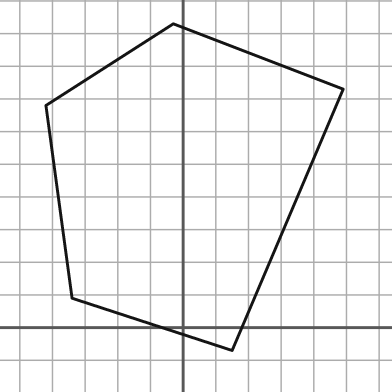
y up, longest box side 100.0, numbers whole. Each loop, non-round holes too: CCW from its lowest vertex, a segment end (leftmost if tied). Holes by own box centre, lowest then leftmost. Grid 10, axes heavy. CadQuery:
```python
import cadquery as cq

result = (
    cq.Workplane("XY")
    .moveTo(15.0, -7.0)
    .lineTo(49.0, 73.0)
    .lineTo(-3.0, 93.0)
    .lineTo(-42.0, 68.0)
    .lineTo(-34.0, 9.0)
    .close()
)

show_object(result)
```